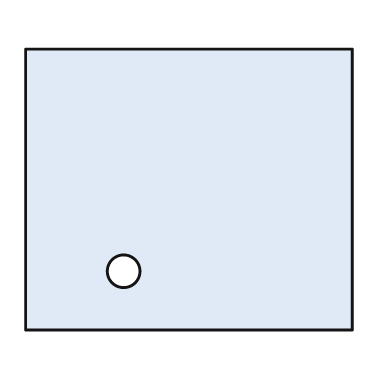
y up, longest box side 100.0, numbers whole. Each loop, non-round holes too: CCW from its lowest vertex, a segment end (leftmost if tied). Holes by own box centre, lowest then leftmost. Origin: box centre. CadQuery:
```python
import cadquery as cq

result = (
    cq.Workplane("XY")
    .moveTo(-50.0, -43.0)
    .lineTo(50.0, -43.0)
    .lineTo(50.0, 43.0)
    .lineTo(-50.0, 43.0)
    .close()
    .moveTo(-20.0, -25.0)
    .circle(5.0)
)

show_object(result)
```